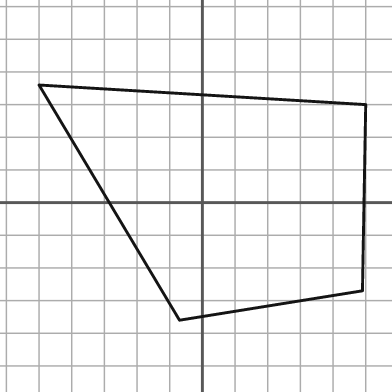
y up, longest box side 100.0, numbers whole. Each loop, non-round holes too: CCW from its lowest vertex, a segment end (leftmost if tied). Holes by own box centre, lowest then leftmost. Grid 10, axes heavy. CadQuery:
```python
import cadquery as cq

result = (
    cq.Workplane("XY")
    .moveTo(-7.0, -36.0)
    .lineTo(49.0, -27.0)
    .lineTo(50.0, 30.0)
    .lineTo(-50.0, 36.0)
    .close()
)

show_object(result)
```